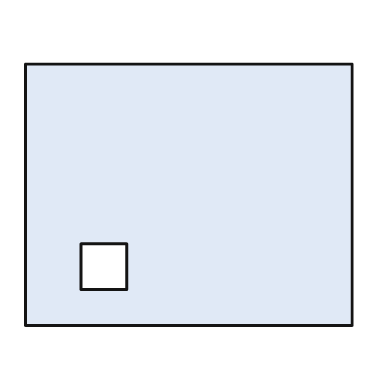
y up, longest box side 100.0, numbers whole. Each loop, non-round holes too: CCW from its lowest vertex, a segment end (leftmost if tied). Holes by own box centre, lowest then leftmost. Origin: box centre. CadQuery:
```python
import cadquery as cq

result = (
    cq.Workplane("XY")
    .moveTo(-50.0, -40.0)
    .lineTo(50.0, -40.0)
    .lineTo(50.0, 40.0)
    .lineTo(-50.0, 40.0)
    .close()
    .moveTo(-33.0, -29.0)
    .lineTo(-19.0, -29.0)
    .lineTo(-19.0, -15.0)
    .lineTo(-33.0, -15.0)
    .close()
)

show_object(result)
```